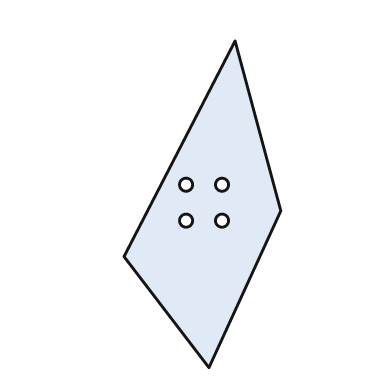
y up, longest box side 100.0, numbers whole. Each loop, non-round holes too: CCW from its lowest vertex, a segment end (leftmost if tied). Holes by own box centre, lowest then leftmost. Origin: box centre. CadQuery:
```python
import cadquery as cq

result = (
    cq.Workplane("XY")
    .moveTo(2.0, -50.0)
    .lineTo(24.0, -2.0)
    .lineTo(10.0, 50.0)
    .lineTo(-24.0, -16.0)
    .close()
    .moveTo(-5.0, -5.0)
    .circle(2.0)
    .moveTo(6.0, -5.0)
    .circle(2.0)
    .moveTo(-5.0, 6.0)
    .circle(2.0)
    .moveTo(6.0, 6.0)
    .circle(2.0)
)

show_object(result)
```